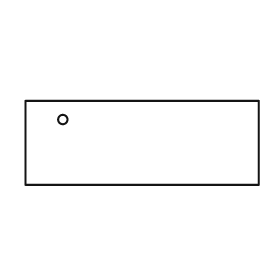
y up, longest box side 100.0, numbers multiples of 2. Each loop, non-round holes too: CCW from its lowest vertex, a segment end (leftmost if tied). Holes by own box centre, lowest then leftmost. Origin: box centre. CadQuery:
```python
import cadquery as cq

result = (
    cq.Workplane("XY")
    .moveTo(-50.0, -18.0)
    .lineTo(50.0, -18.0)
    .lineTo(50.0, 18.0)
    .lineTo(-50.0, 18.0)
    .close()
    .moveTo(-34.0, 10.0)
    .circle(2.0)
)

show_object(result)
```